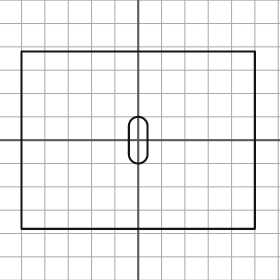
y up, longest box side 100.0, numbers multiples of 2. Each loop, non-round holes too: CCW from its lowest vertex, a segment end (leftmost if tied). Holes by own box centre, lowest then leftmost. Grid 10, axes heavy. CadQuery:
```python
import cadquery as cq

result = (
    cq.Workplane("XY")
    .moveTo(-50.0, -38.0)
    .lineTo(50.0, -38.0)
    .lineTo(50.0, 38.0)
    .lineTo(-50.0, 38.0)
    .close()
    .moveTo(-4.0, -6.0)
    .threePointArc((0.0, -10.0), (4.0, -6.0))
    .lineTo(4.0, 6.0)
    .threePointArc((0.0, 10.0), (-4.0, 6.0))
    .close()
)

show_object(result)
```